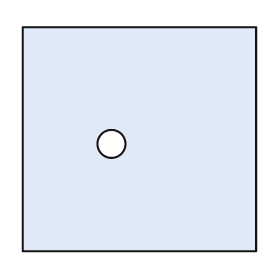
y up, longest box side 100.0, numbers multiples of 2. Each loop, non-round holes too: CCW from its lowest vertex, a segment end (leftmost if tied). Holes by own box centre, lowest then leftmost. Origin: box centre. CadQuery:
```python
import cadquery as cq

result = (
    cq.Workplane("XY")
    .moveTo(-50.0, -48.0)
    .lineTo(50.0, -48.0)
    .lineTo(50.0, 48.0)
    .lineTo(-50.0, 48.0)
    .close()
    .moveTo(-12.0, -2.0)
    .circle(6.0)
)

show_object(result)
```